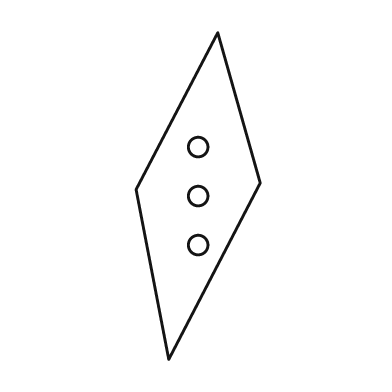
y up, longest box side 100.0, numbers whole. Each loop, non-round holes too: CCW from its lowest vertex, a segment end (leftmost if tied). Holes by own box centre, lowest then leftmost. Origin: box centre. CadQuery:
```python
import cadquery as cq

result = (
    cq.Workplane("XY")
    .moveTo(-9.0, -50.0)
    .lineTo(19.0, 4.0)
    .lineTo(6.0, 50.0)
    .lineTo(-19.0, 2.0)
    .close()
    .moveTo(0.0, -15.0)
    .circle(3.0)
    .moveTo(0.0, 0.0)
    .circle(3.0)
    .moveTo(0.0, 15.0)
    .circle(3.0)
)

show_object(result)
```